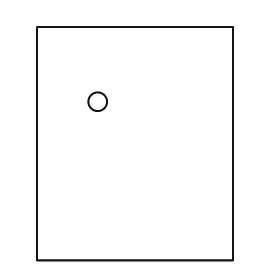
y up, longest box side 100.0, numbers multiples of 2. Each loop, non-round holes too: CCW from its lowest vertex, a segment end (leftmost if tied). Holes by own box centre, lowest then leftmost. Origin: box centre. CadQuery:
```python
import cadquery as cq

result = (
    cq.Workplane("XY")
    .moveTo(-42.0, -50.0)
    .lineTo(42.0, -50.0)
    .lineTo(42.0, 50.0)
    .lineTo(-42.0, 50.0)
    .close()
    .moveTo(-16.0, 18.0)
    .circle(4.0)
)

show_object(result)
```